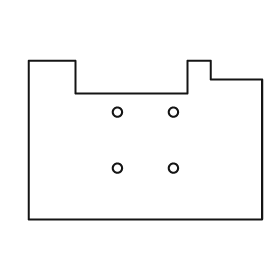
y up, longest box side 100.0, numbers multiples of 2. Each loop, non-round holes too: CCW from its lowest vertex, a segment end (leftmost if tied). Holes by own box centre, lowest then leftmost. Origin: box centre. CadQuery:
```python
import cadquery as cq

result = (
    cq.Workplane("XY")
    .moveTo(-50.0, -34.0)
    .lineTo(50.0, -34.0)
    .lineTo(50.0, 26.0)
    .lineTo(28.0, 26.0)
    .lineTo(28.0, 34.0)
    .lineTo(18.0, 34.0)
    .lineTo(18.0, 20.0)
    .lineTo(-30.0, 20.0)
    .lineTo(-30.0, 34.0)
    .lineTo(-50.0, 34.0)
    .close()
    .moveTo(-12.0, -12.0)
    .circle(2.0)
    .moveTo(12.0, -12.0)
    .circle(2.0)
    .moveTo(-12.0, 12.0)
    .circle(2.0)
    .moveTo(12.0, 12.0)
    .circle(2.0)
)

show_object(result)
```